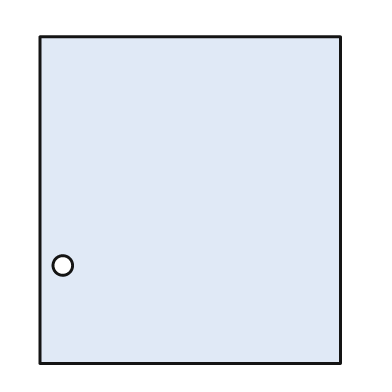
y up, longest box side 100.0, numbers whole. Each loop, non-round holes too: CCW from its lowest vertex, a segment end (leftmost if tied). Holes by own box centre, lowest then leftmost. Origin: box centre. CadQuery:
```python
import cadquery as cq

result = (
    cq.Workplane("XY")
    .moveTo(-46.0, -50.0)
    .lineTo(46.0, -50.0)
    .lineTo(46.0, 50.0)
    .lineTo(-46.0, 50.0)
    .close()
    .moveTo(-39.0, -20.0)
    .circle(3.0)
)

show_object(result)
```